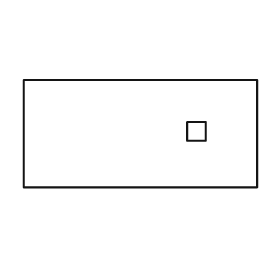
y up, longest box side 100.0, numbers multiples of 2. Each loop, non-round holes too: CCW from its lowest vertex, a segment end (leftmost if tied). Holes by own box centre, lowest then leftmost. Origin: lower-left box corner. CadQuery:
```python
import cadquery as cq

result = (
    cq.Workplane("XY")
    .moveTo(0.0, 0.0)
    .lineTo(100.0, 0.0)
    .lineTo(100.0, 46.0)
    .lineTo(0.0, 46.0)
    .close()
    .moveTo(70.0, 20.0)
    .lineTo(78.0, 20.0)
    .lineTo(78.0, 28.0)
    .lineTo(70.0, 28.0)
    .close()
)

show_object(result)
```